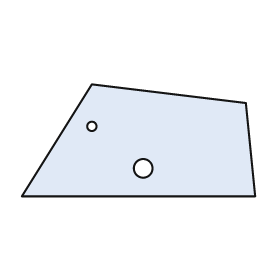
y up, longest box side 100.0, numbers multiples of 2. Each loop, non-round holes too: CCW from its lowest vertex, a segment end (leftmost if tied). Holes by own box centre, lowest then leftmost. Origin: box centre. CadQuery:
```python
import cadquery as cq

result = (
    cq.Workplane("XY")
    .moveTo(-50.0, -24.0)
    .lineTo(50.0, -24.0)
    .lineTo(46.0, 16.0)
    .lineTo(-20.0, 24.0)
    .close()
    .moveTo(2.0, -12.0)
    .circle(4.0)
    .moveTo(-20.0, 6.0)
    .circle(2.0)
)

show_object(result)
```